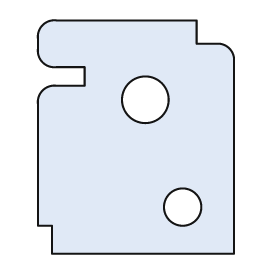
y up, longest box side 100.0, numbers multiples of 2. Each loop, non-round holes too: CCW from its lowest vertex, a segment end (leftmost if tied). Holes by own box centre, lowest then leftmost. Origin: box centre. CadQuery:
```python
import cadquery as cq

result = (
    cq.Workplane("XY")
    .moveTo(-36.0, -50.0)
    .lineTo(42.0, -50.0)
    .lineTo(42.0, 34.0)
    .threePointArc((40.0, 38.0), (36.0, 40.0))
    .lineTo(26.0, 40.0)
    .lineTo(26.0, 50.0)
    .lineTo(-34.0, 50.0)
    .threePointArc((-40.0, 48.0), (-42.0, 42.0))
    .lineTo(-42.0, 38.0)
    .threePointArc((-40.0, 32.0), (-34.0, 30.0))
    .lineTo(-22.0, 30.0)
    .lineTo(-22.0, 22.0)
    .lineTo(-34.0, 22.0)
    .threePointArc((-40.0, 20.0), (-42.0, 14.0))
    .lineTo(-42.0, -38.0)
    .lineTo(-36.0, -38.0)
    .close()
    .moveTo(20.0, -30.0)
    .circle(8.0)
    .moveTo(4.0, 16.0)
    .circle(10.0)
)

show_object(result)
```